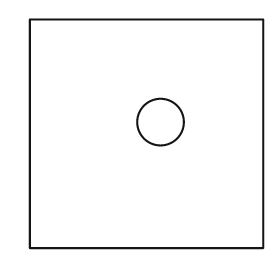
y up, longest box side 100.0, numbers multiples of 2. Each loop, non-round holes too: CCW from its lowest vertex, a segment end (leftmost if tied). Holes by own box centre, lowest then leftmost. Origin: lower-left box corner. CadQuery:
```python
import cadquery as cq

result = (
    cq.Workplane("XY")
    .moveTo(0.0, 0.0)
    .lineTo(100.0, 0.0)
    .lineTo(100.0, 98.0)
    .lineTo(0.0, 98.0)
    .close()
    .moveTo(56.0, 54.0)
    .circle(10.0)
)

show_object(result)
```